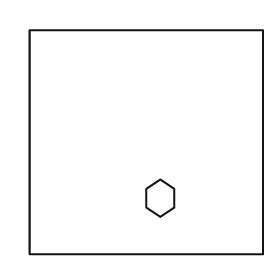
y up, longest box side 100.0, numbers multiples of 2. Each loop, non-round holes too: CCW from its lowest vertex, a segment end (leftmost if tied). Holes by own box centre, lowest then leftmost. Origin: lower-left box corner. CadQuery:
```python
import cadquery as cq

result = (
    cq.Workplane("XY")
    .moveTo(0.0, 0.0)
    .lineTo(100.0, 0.0)
    .lineTo(100.0, 96.0)
    .lineTo(0.0, 96.0)
    .close()
    .moveTo(56.0, 16.0)
    .lineTo(62.0, 20.0)
    .lineTo(62.0, 28.0)
    .lineTo(56.0, 32.0)
    .lineTo(50.0, 28.0)
    .lineTo(50.0, 20.0)
    .close()
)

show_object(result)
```